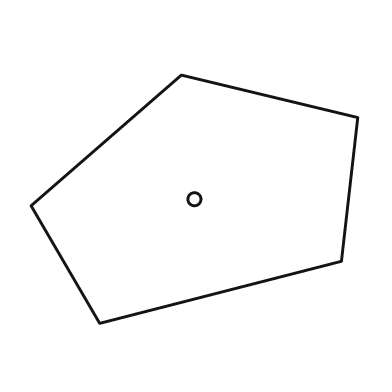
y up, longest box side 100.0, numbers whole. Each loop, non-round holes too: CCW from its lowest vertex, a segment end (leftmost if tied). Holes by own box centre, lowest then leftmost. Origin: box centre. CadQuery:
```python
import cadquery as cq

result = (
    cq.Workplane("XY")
    .moveTo(-29.0, -38.0)
    .lineTo(45.0, -19.0)
    .lineTo(50.0, 25.0)
    .lineTo(-4.0, 38.0)
    .lineTo(-50.0, -2.0)
    .close()
    .moveTo(0.0, 0.0)
    .circle(2.0)
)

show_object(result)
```